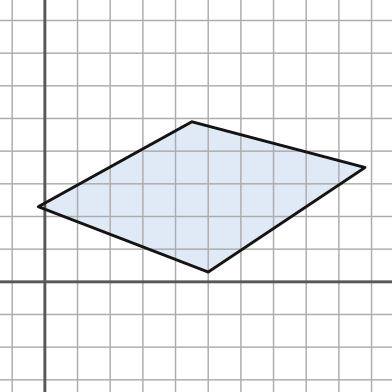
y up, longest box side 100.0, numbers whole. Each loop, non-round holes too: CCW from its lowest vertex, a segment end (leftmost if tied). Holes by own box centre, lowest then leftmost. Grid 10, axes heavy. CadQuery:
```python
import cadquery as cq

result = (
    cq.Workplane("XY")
    .moveTo(50.0, 3.0)
    .lineTo(98.0, 35.0)
    .lineTo(45.0, 49.0)
    .lineTo(-2.0, 23.0)
    .close()
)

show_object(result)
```